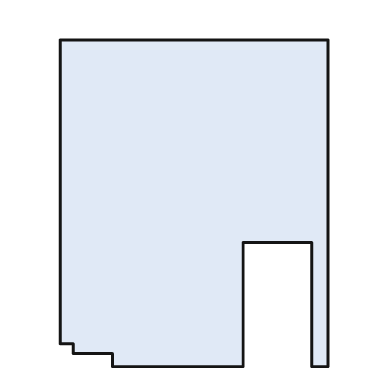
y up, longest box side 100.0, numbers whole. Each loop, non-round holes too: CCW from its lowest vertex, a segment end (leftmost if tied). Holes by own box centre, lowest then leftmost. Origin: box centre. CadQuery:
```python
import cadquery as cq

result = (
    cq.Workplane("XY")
    .moveTo(-25.0, -50.0)
    .lineTo(15.0, -50.0)
    .lineTo(15.0, -12.0)
    .lineTo(36.0, -12.0)
    .lineTo(36.0, -50.0)
    .lineTo(41.0, -50.0)
    .lineTo(41.0, 50.0)
    .lineTo(-41.0, 50.0)
    .lineTo(-41.0, -43.0)
    .lineTo(-37.0, -43.0)
    .lineTo(-37.0, -46.0)
    .lineTo(-25.0, -46.0)
    .close()
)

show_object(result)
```